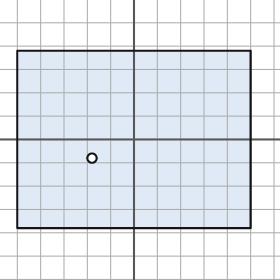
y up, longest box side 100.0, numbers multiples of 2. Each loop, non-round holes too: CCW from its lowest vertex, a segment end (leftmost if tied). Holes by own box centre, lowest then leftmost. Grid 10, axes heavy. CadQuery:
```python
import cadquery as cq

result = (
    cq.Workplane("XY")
    .moveTo(-50.0, -38.0)
    .lineTo(50.0, -38.0)
    .lineTo(50.0, 38.0)
    .lineTo(-50.0, 38.0)
    .close()
    .moveTo(-18.0, -8.0)
    .circle(2.0)
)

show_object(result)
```